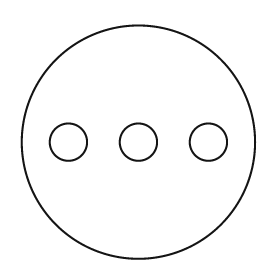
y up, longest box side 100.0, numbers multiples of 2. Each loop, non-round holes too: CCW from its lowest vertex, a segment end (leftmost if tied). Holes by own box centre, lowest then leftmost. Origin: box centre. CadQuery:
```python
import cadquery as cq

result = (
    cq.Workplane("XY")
    .moveTo(0.0, 0.0)
    .circle(50.0)
    .moveTo(-30.0, 0.0)
    .circle(8.0)
    .moveTo(0.0, 0.0)
    .circle(8.0)
    .moveTo(30.0, 0.0)
    .circle(8.0)
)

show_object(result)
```